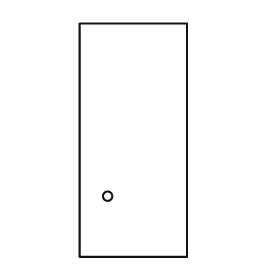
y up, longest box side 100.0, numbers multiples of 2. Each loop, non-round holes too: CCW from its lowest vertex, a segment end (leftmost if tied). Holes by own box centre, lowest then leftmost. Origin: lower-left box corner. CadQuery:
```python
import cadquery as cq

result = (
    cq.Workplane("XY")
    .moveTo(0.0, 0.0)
    .lineTo(46.0, 0.0)
    .lineTo(46.0, 100.0)
    .lineTo(0.0, 100.0)
    .close()
    .moveTo(12.0, 26.0)
    .circle(2.0)
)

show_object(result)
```